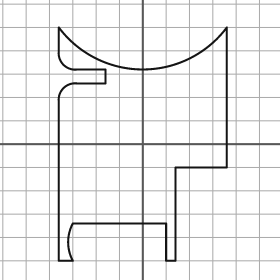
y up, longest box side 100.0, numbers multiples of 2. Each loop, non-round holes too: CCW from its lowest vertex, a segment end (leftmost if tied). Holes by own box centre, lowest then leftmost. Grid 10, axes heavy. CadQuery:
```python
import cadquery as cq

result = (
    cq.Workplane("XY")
    .moveTo(-36.0, -50.0)
    .lineTo(-30.0, -50.0)
    .threePointArc((-32.0, -42.0), (-30.0, -34.0))
    .lineTo(10.0, -34.0)
    .lineTo(10.0, -50.0)
    .lineTo(14.0, -50.0)
    .lineTo(14.0, -10.0)
    .lineTo(36.0, -10.0)
    .lineTo(36.0, 50.0)
    .threePointArc((0.0, 32.0), (-36.0, 50.0))
    .lineTo(-36.0, 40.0)
    .threePointArc((-34.0, 34.0), (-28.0, 32.0))
    .lineTo(-16.0, 32.0)
    .lineTo(-16.0, 26.0)
    .lineTo(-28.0, 26.0)
    .threePointArc((-34.0, 24.0), (-36.0, 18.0))
    .close()
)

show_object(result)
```